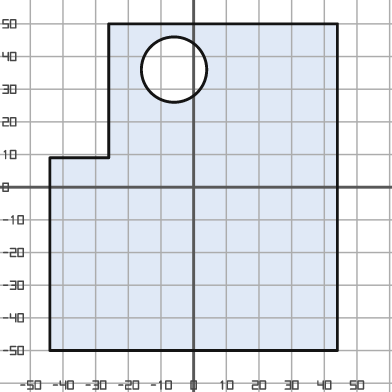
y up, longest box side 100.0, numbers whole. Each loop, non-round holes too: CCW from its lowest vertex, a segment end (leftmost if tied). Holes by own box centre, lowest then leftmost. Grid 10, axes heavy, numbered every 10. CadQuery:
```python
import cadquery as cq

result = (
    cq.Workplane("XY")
    .moveTo(-44.0, -50.0)
    .lineTo(44.0, -50.0)
    .lineTo(44.0, 50.0)
    .lineTo(-26.0, 50.0)
    .lineTo(-26.0, 9.0)
    .lineTo(-44.0, 9.0)
    .close()
    .moveTo(-6.0, 36.0)
    .circle(10.0)
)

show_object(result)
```